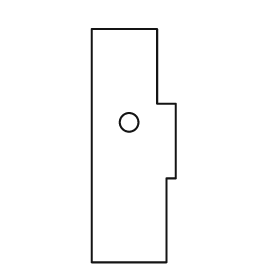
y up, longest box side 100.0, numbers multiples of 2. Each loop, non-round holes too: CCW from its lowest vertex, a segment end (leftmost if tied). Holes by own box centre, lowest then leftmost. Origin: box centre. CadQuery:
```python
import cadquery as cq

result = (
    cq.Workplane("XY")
    .moveTo(-18.0, -50.0)
    .lineTo(14.0, -50.0)
    .lineTo(14.0, -14.0)
    .lineTo(18.0, -14.0)
    .lineTo(18.0, 18.0)
    .lineTo(10.0, 18.0)
    .lineTo(10.0, 50.0)
    .lineTo(-18.0, 50.0)
    .close()
    .moveTo(-2.0, 10.0)
    .circle(4.0)
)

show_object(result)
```